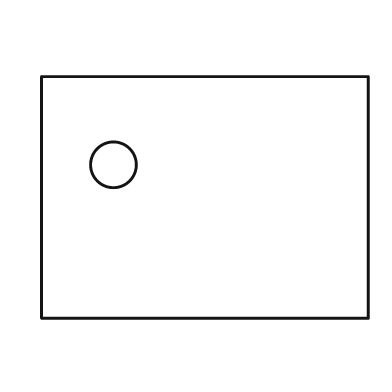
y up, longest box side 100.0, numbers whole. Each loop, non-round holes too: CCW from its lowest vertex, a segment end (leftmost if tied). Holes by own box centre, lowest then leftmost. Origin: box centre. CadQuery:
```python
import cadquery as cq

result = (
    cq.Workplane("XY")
    .moveTo(-50.0, -37.0)
    .lineTo(50.0, -37.0)
    .lineTo(50.0, 37.0)
    .lineTo(-50.0, 37.0)
    .close()
    .moveTo(-28.0, 10.0)
    .circle(7.0)
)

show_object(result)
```